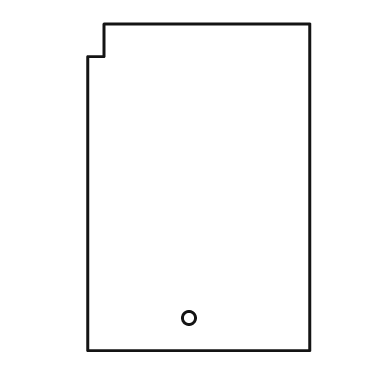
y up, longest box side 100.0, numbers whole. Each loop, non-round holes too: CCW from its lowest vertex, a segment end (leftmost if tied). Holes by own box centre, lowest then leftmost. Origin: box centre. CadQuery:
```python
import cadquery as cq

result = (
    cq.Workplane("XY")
    .moveTo(-34.0, -50.0)
    .lineTo(34.0, -50.0)
    .lineTo(34.0, 50.0)
    .lineTo(-29.0, 50.0)
    .lineTo(-29.0, 40.0)
    .lineTo(-34.0, 40.0)
    .close()
    .moveTo(-3.0, -40.0)
    .circle(2.0)
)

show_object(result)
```